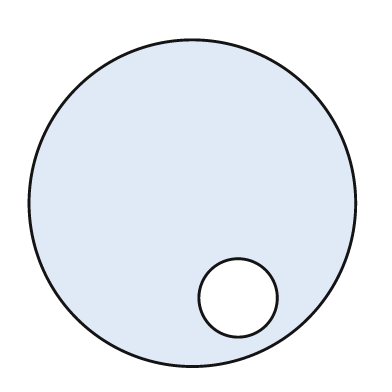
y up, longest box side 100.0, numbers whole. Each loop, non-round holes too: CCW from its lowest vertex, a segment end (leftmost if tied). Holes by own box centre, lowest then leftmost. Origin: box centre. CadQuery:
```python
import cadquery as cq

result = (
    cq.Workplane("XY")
    .moveTo(0.0, 0.0)
    .circle(50.0)
    .moveTo(14.0, -29.0)
    .circle(12.0)
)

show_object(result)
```